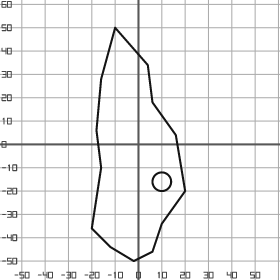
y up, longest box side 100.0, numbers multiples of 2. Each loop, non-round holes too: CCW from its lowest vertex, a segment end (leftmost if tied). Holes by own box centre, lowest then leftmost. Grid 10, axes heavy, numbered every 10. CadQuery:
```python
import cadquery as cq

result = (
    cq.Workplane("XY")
    .moveTo(-2.0, -50.0)
    .lineTo(6.0, -46.0)
    .lineTo(10.0, -34.0)
    .lineTo(20.0, -20.0)
    .lineTo(16.0, 4.0)
    .lineTo(6.0, 18.0)
    .lineTo(4.0, 34.0)
    .lineTo(-10.0, 50.0)
    .lineTo(-16.0, 28.0)
    .lineTo(-18.0, 6.0)
    .lineTo(-16.0, -10.0)
    .lineTo(-20.0, -36.0)
    .lineTo(-12.0, -44.0)
    .close()
    .moveTo(10.0, -16.0)
    .circle(4.0)
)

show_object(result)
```